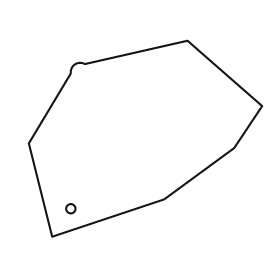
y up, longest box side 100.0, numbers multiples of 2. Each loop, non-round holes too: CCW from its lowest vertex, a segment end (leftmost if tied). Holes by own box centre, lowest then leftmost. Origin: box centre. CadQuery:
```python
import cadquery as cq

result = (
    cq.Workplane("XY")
    .moveTo(-40.0, -42.0)
    .lineTo(8.0, -26.0)
    .lineTo(38.0, -4.0)
    .lineTo(50.0, 14.0)
    .lineTo(18.0, 42.0)
    .lineTo(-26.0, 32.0)
    .threePointArc((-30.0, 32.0), (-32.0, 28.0))
    .lineTo(-50.0, -2.0)
    .close()
    .moveTo(-32.0, -30.0)
    .circle(2.0)
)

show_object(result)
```